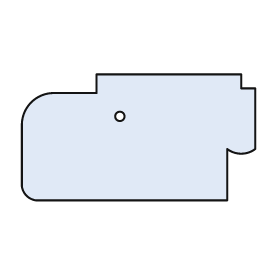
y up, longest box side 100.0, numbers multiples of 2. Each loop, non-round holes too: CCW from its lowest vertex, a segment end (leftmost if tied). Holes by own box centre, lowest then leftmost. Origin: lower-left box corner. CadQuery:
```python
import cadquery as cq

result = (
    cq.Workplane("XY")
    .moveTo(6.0, 0.0)
    .lineTo(88.0, 0.0)
    .lineTo(88.0, 22.0)
    .threePointArc((94.0, 20.0), (100.0, 22.0))
    .lineTo(100.0, 48.0)
    .lineTo(94.0, 48.0)
    .lineTo(94.0, 54.0)
    .lineTo(32.0, 54.0)
    .lineTo(32.0, 46.0)
    .lineTo(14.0, 46.0)
    .threePointArc((4.0, 42.0), (0.0, 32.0))
    .lineTo(0.0, 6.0)
    .threePointArc((2.0, 2.0), (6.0, 0.0))
    .close()
    .moveTo(42.0, 36.0)
    .circle(2.0)
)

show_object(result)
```